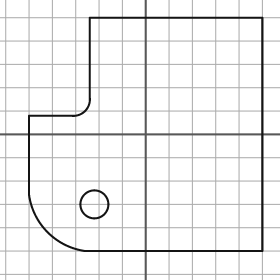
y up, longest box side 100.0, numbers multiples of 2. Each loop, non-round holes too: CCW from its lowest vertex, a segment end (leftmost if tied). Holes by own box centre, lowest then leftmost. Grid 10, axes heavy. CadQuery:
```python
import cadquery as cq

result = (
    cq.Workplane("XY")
    .moveTo(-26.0, -50.0)
    .lineTo(50.0, -50.0)
    .lineTo(50.0, 50.0)
    .lineTo(-24.0, 50.0)
    .lineTo(-24.0, 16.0)
    .threePointArc((-26.0, 10.0), (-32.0, 8.0))
    .lineTo(-50.0, 8.0)
    .lineTo(-50.0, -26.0)
    .threePointArc((-42.0, -42.0), (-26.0, -50.0))
    .close()
    .moveTo(-22.0, -30.0)
    .circle(6.0)
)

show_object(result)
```